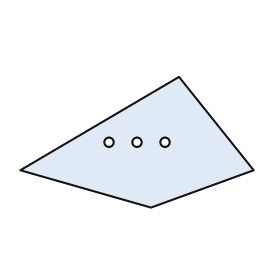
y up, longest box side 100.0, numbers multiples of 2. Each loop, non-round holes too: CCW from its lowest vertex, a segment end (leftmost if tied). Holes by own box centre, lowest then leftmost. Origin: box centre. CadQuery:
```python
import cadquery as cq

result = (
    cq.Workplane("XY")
    .moveTo(6.0, -28.0)
    .lineTo(50.0, -12.0)
    .lineTo(18.0, 28.0)
    .lineTo(-50.0, -12.0)
    .close()
    .moveTo(-12.0, 0.0)
    .circle(2.0)
    .moveTo(0.0, 0.0)
    .circle(2.0)
    .moveTo(12.0, 0.0)
    .circle(2.0)
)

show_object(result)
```